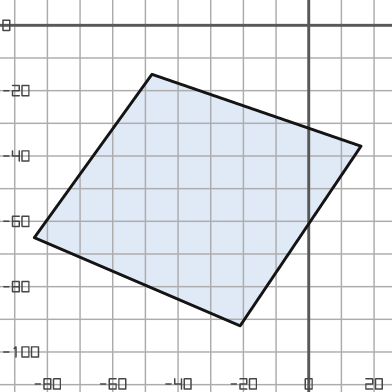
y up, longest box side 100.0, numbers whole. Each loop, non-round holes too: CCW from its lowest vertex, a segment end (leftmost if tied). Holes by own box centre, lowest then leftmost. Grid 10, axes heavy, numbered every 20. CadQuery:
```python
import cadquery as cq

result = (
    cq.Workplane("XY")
    .moveTo(-21.0, -92.0)
    .lineTo(16.0, -37.0)
    .lineTo(-48.0, -15.0)
    .lineTo(-84.0, -65.0)
    .close()
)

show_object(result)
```